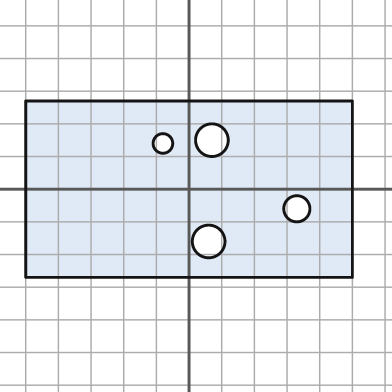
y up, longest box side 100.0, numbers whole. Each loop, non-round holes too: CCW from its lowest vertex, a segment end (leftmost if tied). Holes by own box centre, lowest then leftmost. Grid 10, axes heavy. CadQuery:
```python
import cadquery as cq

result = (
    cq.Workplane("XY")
    .moveTo(-50.0, -27.0)
    .lineTo(50.0, -27.0)
    .lineTo(50.0, 27.0)
    .lineTo(-50.0, 27.0)
    .close()
    .moveTo(6.0, -16.0)
    .circle(5.0)
    .moveTo(33.0, -6.0)
    .circle(4.0)
    .moveTo(-8.0, 14.0)
    .circle(3.0)
    .moveTo(7.0, 15.0)
    .circle(5.0)
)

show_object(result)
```